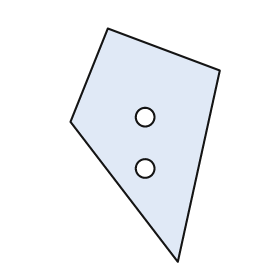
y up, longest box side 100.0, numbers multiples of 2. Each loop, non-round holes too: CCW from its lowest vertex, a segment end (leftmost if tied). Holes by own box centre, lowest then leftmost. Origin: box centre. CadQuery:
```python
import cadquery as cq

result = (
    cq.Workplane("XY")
    .moveTo(14.0, -50.0)
    .lineTo(32.0, 32.0)
    .lineTo(-16.0, 50.0)
    .lineTo(-32.0, 10.0)
    .close()
    .moveTo(0.0, -10.0)
    .circle(4.0)
    .moveTo(0.0, 12.0)
    .circle(4.0)
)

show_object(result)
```